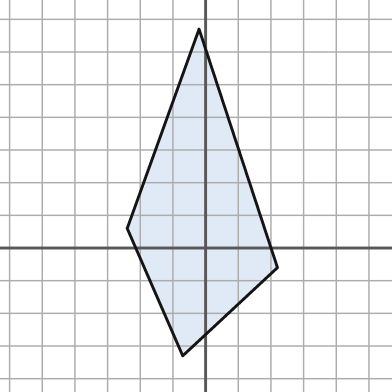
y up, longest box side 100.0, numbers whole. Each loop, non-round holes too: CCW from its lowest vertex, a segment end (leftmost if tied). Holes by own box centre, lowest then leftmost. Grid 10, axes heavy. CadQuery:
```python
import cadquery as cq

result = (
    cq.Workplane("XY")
    .moveTo(-7.0, -33.0)
    .lineTo(22.0, -6.0)
    .lineTo(-2.0, 67.0)
    .lineTo(-24.0, 6.0)
    .close()
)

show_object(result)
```